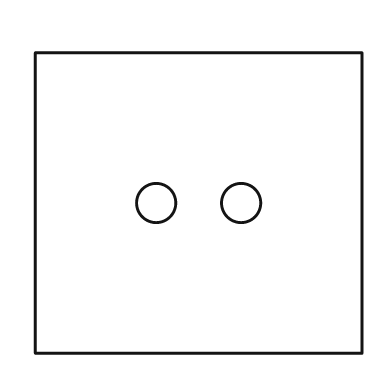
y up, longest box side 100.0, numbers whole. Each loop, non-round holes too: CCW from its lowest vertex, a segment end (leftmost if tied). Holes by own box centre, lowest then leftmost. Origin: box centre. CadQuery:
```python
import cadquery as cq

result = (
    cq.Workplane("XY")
    .moveTo(-50.0, -46.0)
    .lineTo(50.0, -46.0)
    .lineTo(50.0, 46.0)
    .lineTo(-50.0, 46.0)
    .close()
    .moveTo(-13.0, 0.0)
    .circle(6.0)
    .moveTo(13.0, 0.0)
    .circle(6.0)
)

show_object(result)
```